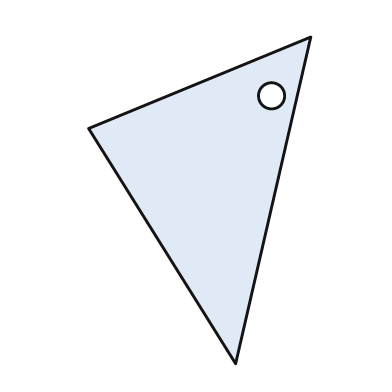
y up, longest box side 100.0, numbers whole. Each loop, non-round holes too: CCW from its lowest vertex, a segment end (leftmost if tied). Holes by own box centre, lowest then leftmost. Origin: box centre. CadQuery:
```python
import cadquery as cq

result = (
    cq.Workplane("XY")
    .moveTo(11.0, -50.0)
    .lineTo(34.0, 50.0)
    .lineTo(-34.0, 22.0)
    .close()
    .moveTo(22.0, 32.0)
    .circle(4.0)
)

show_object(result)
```